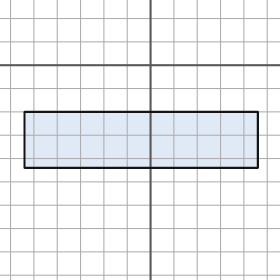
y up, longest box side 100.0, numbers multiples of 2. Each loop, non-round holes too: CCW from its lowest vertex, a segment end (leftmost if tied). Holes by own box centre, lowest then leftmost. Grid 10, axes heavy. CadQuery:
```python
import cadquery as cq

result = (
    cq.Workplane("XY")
    .moveTo(-54.0, -44.0)
    .lineTo(46.0, -44.0)
    .lineTo(46.0, -20.0)
    .lineTo(-54.0, -20.0)
    .close()
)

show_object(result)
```